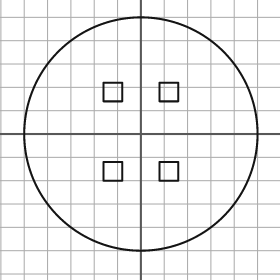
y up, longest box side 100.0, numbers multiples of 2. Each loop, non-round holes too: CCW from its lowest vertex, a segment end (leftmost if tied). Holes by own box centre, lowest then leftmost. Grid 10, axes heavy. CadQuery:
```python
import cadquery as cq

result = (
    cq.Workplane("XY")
    .moveTo(0.0, 0.0)
    .circle(50.0)
    .moveTo(-16.0, -20.0)
    .lineTo(-8.0, -20.0)
    .lineTo(-8.0, -12.0)
    .lineTo(-16.0, -12.0)
    .close()
    .moveTo(8.0, -20.0)
    .lineTo(16.0, -20.0)
    .lineTo(16.0, -12.0)
    .lineTo(8.0, -12.0)
    .close()
    .moveTo(-16.0, 14.0)
    .lineTo(-8.0, 14.0)
    .lineTo(-8.0, 22.0)
    .lineTo(-16.0, 22.0)
    .close()
    .moveTo(8.0, 14.0)
    .lineTo(16.0, 14.0)
    .lineTo(16.0, 22.0)
    .lineTo(8.0, 22.0)
    .close()
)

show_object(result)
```